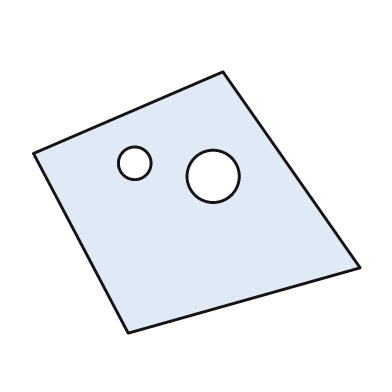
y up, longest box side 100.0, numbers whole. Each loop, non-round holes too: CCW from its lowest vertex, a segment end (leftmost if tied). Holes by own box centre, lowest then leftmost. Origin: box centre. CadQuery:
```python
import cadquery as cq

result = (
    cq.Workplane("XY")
    .moveTo(-21.0, -40.0)
    .lineTo(50.0, -20.0)
    .lineTo(8.0, 40.0)
    .lineTo(-50.0, 15.0)
    .close()
    .moveTo(5.0, 8.0)
    .circle(8.0)
    .moveTo(-19.0, 12.0)
    .circle(5.0)
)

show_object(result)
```